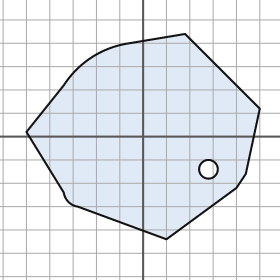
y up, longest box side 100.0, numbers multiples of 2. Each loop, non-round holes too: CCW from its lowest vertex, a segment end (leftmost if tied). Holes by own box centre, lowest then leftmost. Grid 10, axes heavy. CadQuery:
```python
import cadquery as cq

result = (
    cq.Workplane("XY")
    .moveTo(10.0, -44.0)
    .lineTo(40.0, -22.0)
    .lineTo(44.0, -16.0)
    .lineTo(50.0, 12.0)
    .lineTo(18.0, 44.0)
    .lineTo(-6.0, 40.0)
    .threePointArc((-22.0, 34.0), (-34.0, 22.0))
    .lineTo(-50.0, 2.0)
    .lineTo(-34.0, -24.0)
    .threePointArc((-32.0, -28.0), (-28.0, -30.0))
    .close()
    .moveTo(28.0, -14.0)
    .circle(4.0)
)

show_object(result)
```